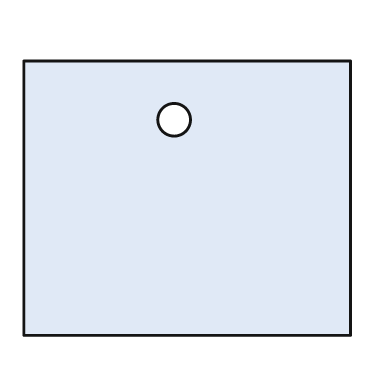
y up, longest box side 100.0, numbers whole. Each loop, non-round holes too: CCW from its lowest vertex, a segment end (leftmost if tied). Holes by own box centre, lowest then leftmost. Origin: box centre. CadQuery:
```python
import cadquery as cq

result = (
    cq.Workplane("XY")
    .moveTo(-50.0, -42.0)
    .lineTo(50.0, -42.0)
    .lineTo(50.0, 42.0)
    .lineTo(-50.0, 42.0)
    .close()
    .moveTo(-4.0, 24.0)
    .circle(5.0)
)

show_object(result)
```